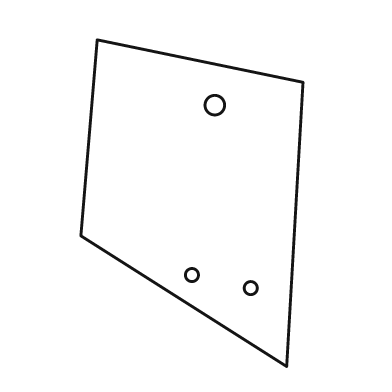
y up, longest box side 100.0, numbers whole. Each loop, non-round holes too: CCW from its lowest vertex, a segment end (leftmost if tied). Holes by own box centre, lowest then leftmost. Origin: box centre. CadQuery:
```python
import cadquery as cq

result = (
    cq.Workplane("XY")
    .moveTo(29.0, -50.0)
    .lineTo(34.0, 37.0)
    .lineTo(-29.0, 50.0)
    .lineTo(-34.0, -10.0)
    .close()
    .moveTo(18.0, -26.0)
    .circle(2.0)
    .moveTo(0.0, -22.0)
    .circle(2.0)
    .moveTo(7.0, 30.0)
    .circle(3.0)
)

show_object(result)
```